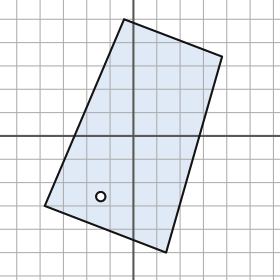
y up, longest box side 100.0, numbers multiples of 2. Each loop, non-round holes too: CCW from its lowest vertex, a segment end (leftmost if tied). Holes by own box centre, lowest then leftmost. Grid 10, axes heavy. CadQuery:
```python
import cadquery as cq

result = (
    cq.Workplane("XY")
    .moveTo(14.0, -50.0)
    .lineTo(38.0, 34.0)
    .lineTo(-4.0, 50.0)
    .lineTo(-38.0, -30.0)
    .close()
    .moveTo(-14.0, -26.0)
    .circle(2.0)
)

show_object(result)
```